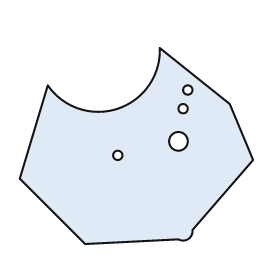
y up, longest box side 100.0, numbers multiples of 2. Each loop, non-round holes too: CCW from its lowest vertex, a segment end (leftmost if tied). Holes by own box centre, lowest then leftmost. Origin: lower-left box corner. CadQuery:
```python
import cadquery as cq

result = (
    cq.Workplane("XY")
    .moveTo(28.0, 0.0)
    .lineTo(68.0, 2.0)
    .threePointArc((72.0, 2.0), (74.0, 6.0))
    .lineTo(100.0, 36.0)
    .lineTo(90.0, 60.0)
    .lineTo(60.0, 84.0)
    .threePointArc((42.0, 58.0), (12.0, 68.0))
    .lineTo(0.0, 28.0)
    .close()
    .moveTo(42.0, 38.0)
    .circle(2.0)
    .moveTo(68.0, 44.0)
    .circle(4.0)
    .moveTo(70.0, 58.0)
    .circle(2.0)
    .moveTo(72.0, 66.0)
    .circle(2.0)
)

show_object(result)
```